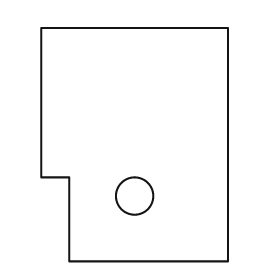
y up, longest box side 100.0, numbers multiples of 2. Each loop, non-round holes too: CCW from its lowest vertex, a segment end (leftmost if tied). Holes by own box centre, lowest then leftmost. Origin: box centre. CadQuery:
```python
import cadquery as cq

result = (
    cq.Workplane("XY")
    .moveTo(-28.0, -50.0)
    .lineTo(40.0, -50.0)
    .lineTo(40.0, 50.0)
    .lineTo(-40.0, 50.0)
    .lineTo(-40.0, -14.0)
    .lineTo(-28.0, -14.0)
    .close()
    .moveTo(0.0, -22.0)
    .circle(8.0)
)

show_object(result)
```